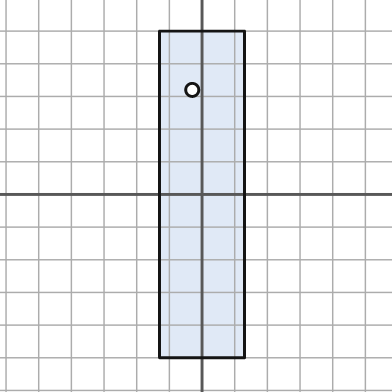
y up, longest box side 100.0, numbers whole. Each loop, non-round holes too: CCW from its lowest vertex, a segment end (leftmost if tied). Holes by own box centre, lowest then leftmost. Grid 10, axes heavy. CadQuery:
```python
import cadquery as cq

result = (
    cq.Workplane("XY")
    .moveTo(-13.0, -50.0)
    .lineTo(13.0, -50.0)
    .lineTo(13.0, 50.0)
    .lineTo(-13.0, 50.0)
    .close()
    .moveTo(-3.0, 32.0)
    .circle(2.0)
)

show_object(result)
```